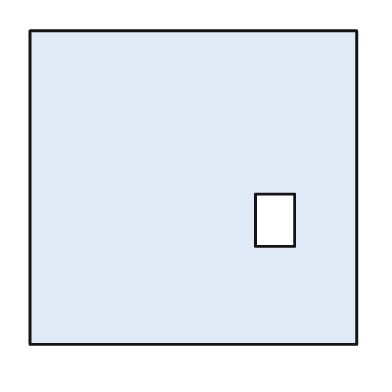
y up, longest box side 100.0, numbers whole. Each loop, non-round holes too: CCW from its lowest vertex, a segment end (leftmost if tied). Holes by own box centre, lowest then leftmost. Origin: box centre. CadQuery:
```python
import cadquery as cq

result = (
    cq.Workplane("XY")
    .moveTo(-50.0, -48.0)
    .lineTo(50.0, -48.0)
    .lineTo(50.0, 48.0)
    .lineTo(-50.0, 48.0)
    .close()
    .moveTo(19.0, -18.0)
    .lineTo(31.0, -18.0)
    .lineTo(31.0, -2.0)
    .lineTo(19.0, -2.0)
    .close()
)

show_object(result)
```